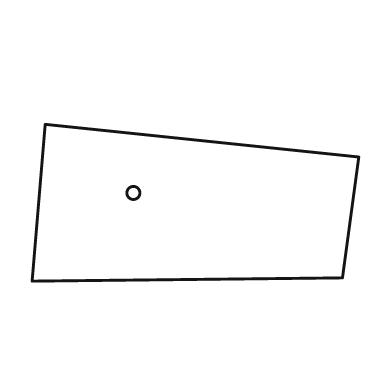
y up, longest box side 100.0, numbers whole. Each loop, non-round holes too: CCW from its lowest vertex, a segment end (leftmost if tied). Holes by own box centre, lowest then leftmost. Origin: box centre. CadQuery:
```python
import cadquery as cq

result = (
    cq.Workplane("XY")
    .moveTo(-50.0, -24.0)
    .lineTo(45.0, -23.0)
    .lineTo(50.0, 14.0)
    .lineTo(-46.0, 24.0)
    .close()
    .moveTo(-19.0, 3.0)
    .circle(2.0)
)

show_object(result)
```